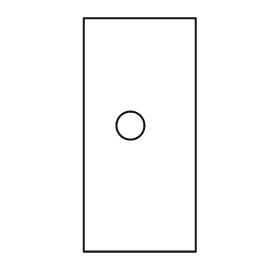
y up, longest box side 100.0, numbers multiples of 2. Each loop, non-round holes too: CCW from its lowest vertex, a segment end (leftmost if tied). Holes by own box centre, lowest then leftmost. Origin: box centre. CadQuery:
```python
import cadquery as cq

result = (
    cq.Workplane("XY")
    .moveTo(-24.0, -50.0)
    .lineTo(24.0, -50.0)
    .lineTo(24.0, 50.0)
    .lineTo(-24.0, 50.0)
    .close()
    .moveTo(-4.0, 4.0)
    .circle(6.0)
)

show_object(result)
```